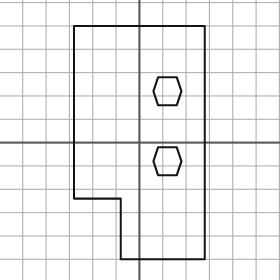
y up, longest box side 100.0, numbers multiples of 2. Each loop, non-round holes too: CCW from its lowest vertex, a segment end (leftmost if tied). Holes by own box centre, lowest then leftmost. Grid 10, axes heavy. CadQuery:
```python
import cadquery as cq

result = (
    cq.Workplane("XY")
    .moveTo(-8.0, -50.0)
    .lineTo(28.0, -50.0)
    .lineTo(28.0, 50.0)
    .lineTo(-28.0, 50.0)
    .lineTo(-28.0, -24.0)
    .lineTo(-8.0, -24.0)
    .close()
    .moveTo(8.0, -14.0)
    .lineTo(16.0, -14.0)
    .lineTo(18.0, -8.0)
    .lineTo(16.0, -2.0)
    .lineTo(8.0, -2.0)
    .lineTo(6.0, -8.0)
    .close()
    .moveTo(8.0, 16.0)
    .lineTo(16.0, 16.0)
    .lineTo(18.0, 22.0)
    .lineTo(16.0, 28.0)
    .lineTo(8.0, 28.0)
    .lineTo(6.0, 22.0)
    .close()
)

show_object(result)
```